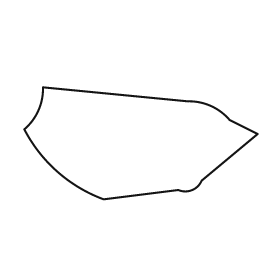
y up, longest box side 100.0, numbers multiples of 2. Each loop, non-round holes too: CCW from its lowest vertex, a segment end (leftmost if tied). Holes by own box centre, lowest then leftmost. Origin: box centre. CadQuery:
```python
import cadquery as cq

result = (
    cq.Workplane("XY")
    .moveTo(-16.0, -24.0)
    .lineTo(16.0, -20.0)
    .threePointArc((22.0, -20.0), (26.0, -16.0))
    .lineTo(50.0, 4.0)
    .lineTo(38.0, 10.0)
    .threePointArc((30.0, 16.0), (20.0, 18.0))
    .lineTo(-42.0, 24.0)
    .threePointArc((-44.0, 14.0), (-50.0, 6.0))
    .threePointArc((-36.0, -12.0), (-16.0, -24.0))
    .close()
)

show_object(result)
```